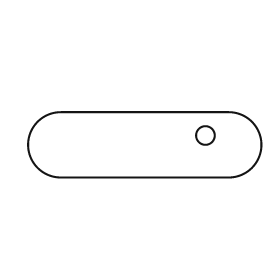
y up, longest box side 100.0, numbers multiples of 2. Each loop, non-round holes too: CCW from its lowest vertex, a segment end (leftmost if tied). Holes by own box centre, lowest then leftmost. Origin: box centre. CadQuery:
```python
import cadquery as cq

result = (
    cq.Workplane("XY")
    .moveTo(-36.0, -14.0)
    .lineTo(36.0, -14.0)
    .threePointArc((50.0, 0.0), (36.0, 14.0))
    .lineTo(-36.0, 14.0)
    .threePointArc((-50.0, 0.0), (-36.0, -14.0))
    .close()
    .moveTo(26.0, 4.0)
    .circle(4.0)
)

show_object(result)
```